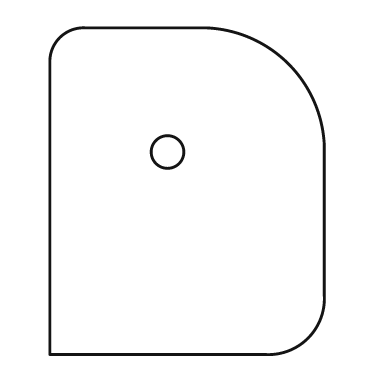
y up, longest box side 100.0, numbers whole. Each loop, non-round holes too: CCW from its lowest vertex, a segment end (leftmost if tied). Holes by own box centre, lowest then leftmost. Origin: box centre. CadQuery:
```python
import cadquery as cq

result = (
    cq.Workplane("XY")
    .moveTo(-42.0, -50.0)
    .lineTo(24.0, -50.0)
    .threePointArc((37.0, -45.0), (42.0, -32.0))
    .lineTo(42.0, 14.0)
    .threePointArc((31.0, 39.0), (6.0, 50.0))
    .lineTo(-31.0, 50.0)
    .threePointArc((-39.0, 47.0), (-42.0, 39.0))
    .close()
    .moveTo(-6.0, 12.0)
    .circle(5.0)
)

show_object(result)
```